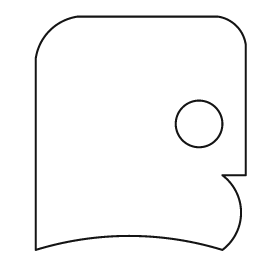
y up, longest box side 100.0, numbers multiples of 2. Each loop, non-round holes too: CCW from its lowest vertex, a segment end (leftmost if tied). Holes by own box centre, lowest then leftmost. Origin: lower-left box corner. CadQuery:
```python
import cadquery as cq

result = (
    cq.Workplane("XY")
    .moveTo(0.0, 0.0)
    .threePointArc((40.0, 6.0), (80.0, 0.0))
    .threePointArc((88.0, 16.0), (80.0, 32.0))
    .lineTo(90.0, 32.0)
    .lineTo(90.0, 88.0)
    .threePointArc((86.0, 96.0), (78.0, 100.0))
    .lineTo(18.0, 100.0)
    .threePointArc((6.0, 94.0), (0.0, 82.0))
    .close()
    .moveTo(70.0, 54.0)
    .circle(10.0)
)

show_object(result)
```